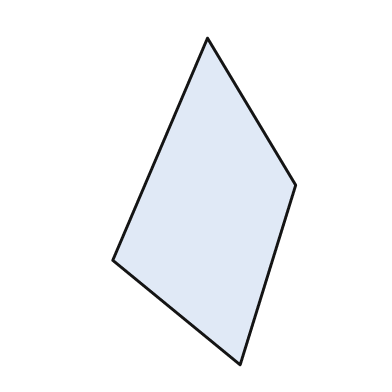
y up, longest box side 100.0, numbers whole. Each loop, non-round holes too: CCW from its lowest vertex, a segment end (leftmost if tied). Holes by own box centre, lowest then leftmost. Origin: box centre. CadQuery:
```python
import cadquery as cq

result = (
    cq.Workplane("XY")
    .moveTo(11.0, -50.0)
    .lineTo(28.0, 5.0)
    .lineTo(1.0, 50.0)
    .lineTo(-28.0, -18.0)
    .close()
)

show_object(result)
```